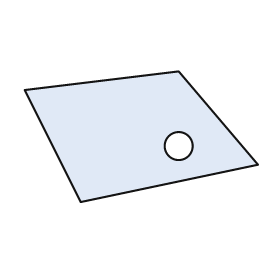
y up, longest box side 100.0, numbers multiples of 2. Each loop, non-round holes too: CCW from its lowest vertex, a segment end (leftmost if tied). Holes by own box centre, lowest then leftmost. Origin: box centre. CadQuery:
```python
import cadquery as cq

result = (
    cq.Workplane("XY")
    .moveTo(-26.0, -28.0)
    .lineTo(50.0, -12.0)
    .lineTo(16.0, 28.0)
    .lineTo(-50.0, 20.0)
    .close()
    .moveTo(16.0, -4.0)
    .circle(6.0)
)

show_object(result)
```